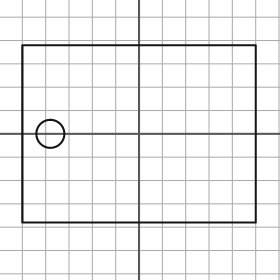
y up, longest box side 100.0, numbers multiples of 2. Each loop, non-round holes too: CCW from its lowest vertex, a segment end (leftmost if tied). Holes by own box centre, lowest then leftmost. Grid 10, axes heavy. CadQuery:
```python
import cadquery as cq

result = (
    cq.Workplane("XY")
    .moveTo(-50.0, -38.0)
    .lineTo(50.0, -38.0)
    .lineTo(50.0, 38.0)
    .lineTo(-50.0, 38.0)
    .close()
    .moveTo(-38.0, 0.0)
    .circle(6.0)
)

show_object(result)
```